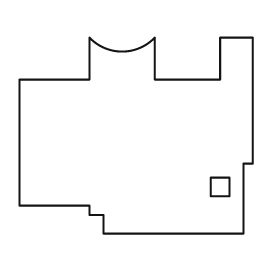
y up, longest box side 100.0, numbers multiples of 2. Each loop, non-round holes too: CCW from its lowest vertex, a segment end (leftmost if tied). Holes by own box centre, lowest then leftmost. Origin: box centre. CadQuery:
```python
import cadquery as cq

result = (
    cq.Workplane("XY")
    .moveTo(-14.0, -42.0)
    .lineTo(46.0, -42.0)
    .lineTo(46.0, -12.0)
    .lineTo(50.0, -12.0)
    .lineTo(50.0, 42.0)
    .lineTo(36.0, 42.0)
    .lineTo(36.0, 24.0)
    .lineTo(8.0, 24.0)
    .lineTo(8.0, 42.0)
    .threePointArc((-6.0, 36.0), (-20.0, 42.0))
    .lineTo(-20.0, 24.0)
    .lineTo(-50.0, 24.0)
    .lineTo(-50.0, -30.0)
    .lineTo(-20.0, -30.0)
    .lineTo(-20.0, -34.0)
    .lineTo(-14.0, -34.0)
    .close()
    .moveTo(32.0, -26.0)
    .lineTo(40.0, -26.0)
    .lineTo(40.0, -18.0)
    .lineTo(32.0, -18.0)
    .close()
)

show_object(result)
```